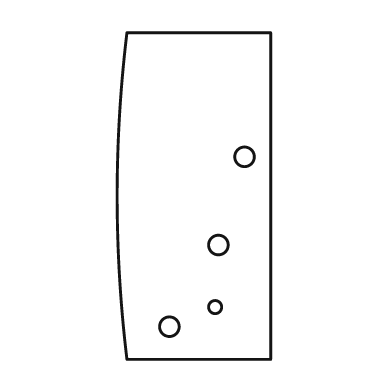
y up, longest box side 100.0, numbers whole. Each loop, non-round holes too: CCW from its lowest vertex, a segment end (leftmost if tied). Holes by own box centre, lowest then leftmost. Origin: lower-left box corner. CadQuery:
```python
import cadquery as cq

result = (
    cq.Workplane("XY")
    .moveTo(3.0, 0.0)
    .lineTo(47.0, 0.0)
    .lineTo(47.0, 100.0)
    .lineTo(3.0, 100.0)
    .threePointArc((0.0, 50.0), (3.0, 0.0))
    .close()
    .moveTo(16.0, 10.0)
    .circle(3.0)
    .moveTo(30.0, 16.0)
    .circle(2.0)
    .moveTo(31.0, 35.0)
    .circle(3.0)
    .moveTo(39.0, 62.0)
    .circle(3.0)
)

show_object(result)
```